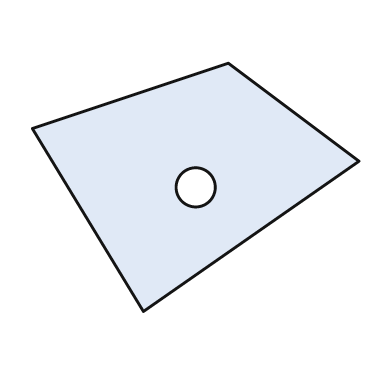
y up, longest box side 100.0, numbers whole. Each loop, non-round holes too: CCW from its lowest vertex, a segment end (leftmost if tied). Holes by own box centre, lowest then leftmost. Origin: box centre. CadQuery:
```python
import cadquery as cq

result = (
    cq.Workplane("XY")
    .moveTo(-16.0, -38.0)
    .lineTo(50.0, 8.0)
    .lineTo(10.0, 38.0)
    .lineTo(-50.0, 18.0)
    .close()
    .moveTo(0.0, 0.0)
    .circle(6.0)
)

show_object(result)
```